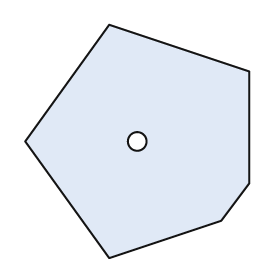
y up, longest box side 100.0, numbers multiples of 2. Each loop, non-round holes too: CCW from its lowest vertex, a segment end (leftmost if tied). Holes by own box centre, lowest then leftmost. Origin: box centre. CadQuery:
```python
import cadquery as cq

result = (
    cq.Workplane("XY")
    .moveTo(-12.0, -50.0)
    .lineTo(36.0, -34.0)
    .lineTo(48.0, -18.0)
    .lineTo(48.0, 30.0)
    .lineTo(-12.0, 50.0)
    .lineTo(-48.0, 0.0)
    .close()
    .moveTo(0.0, 0.0)
    .circle(4.0)
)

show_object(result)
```